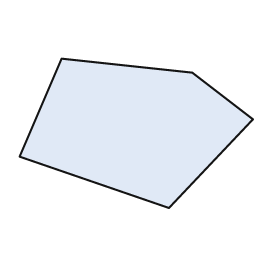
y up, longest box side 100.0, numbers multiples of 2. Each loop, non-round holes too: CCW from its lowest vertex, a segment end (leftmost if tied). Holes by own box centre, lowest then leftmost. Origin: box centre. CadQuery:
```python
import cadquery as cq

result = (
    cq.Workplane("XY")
    .moveTo(14.0, -32.0)
    .lineTo(50.0, 6.0)
    .lineTo(24.0, 26.0)
    .lineTo(-32.0, 32.0)
    .lineTo(-50.0, -10.0)
    .close()
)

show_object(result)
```